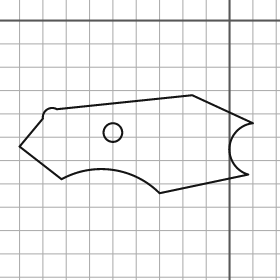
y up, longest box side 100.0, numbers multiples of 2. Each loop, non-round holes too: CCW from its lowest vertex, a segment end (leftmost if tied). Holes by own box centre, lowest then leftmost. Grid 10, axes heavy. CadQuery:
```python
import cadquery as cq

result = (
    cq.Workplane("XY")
    .moveTo(-30.0, -74.0)
    .lineTo(8.0, -66.0)
    .threePointArc((0.0, -54.0), (10.0, -44.0))
    .lineTo(-16.0, -32.0)
    .lineTo(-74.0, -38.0)
    .threePointArc((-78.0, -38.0), (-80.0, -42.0))
    .lineTo(-90.0, -54.0)
    .lineTo(-72.0, -68.0)
    .threePointArc((-50.0, -64.0), (-30.0, -74.0))
    .close()
    .moveTo(-50.0, -48.0)
    .circle(4.0)
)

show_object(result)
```